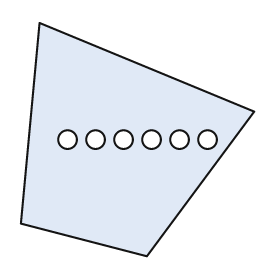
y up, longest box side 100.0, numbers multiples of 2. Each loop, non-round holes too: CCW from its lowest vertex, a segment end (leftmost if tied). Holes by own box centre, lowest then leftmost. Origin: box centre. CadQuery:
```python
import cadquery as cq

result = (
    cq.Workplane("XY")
    .moveTo(4.0, -50.0)
    .lineTo(50.0, 12.0)
    .lineTo(-42.0, 50.0)
    .lineTo(-50.0, -36.0)
    .close()
    .moveTo(-30.0, 0.0)
    .circle(4.0)
    .moveTo(-18.0, 0.0)
    .circle(4.0)
    .moveTo(-6.0, 0.0)
    .circle(4.0)
    .moveTo(6.0, 0.0)
    .circle(4.0)
    .moveTo(18.0, 0.0)
    .circle(4.0)
    .moveTo(30.0, 0.0)
    .circle(4.0)
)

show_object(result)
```